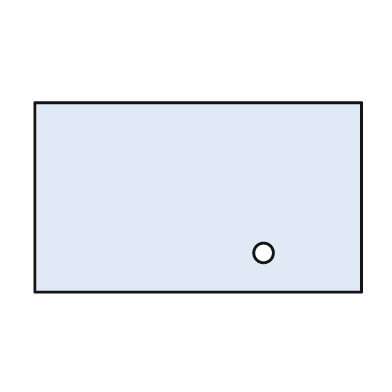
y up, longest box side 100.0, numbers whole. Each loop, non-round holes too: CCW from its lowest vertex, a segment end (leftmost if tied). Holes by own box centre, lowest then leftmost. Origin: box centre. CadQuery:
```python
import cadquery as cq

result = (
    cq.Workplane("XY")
    .moveTo(-50.0, -29.0)
    .lineTo(50.0, -29.0)
    .lineTo(50.0, 29.0)
    .lineTo(-50.0, 29.0)
    .close()
    .moveTo(20.0, -17.0)
    .circle(3.0)
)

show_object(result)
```